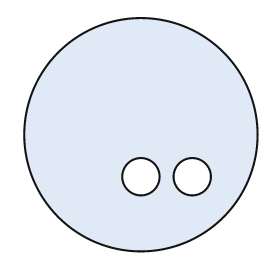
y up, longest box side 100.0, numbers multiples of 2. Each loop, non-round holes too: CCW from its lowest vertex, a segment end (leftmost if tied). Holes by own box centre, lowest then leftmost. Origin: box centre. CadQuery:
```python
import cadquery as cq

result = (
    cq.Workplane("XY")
    .moveTo(0.0, 0.0)
    .circle(50.0)
    .moveTo(0.0, -18.0)
    .circle(8.0)
    .moveTo(22.0, -18.0)
    .circle(8.0)
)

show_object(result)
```